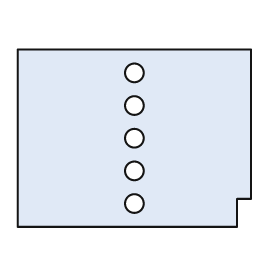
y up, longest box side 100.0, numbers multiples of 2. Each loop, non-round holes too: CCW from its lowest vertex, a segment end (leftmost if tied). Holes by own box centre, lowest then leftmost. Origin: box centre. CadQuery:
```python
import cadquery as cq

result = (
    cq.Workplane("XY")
    .moveTo(-50.0, -38.0)
    .lineTo(44.0, -38.0)
    .lineTo(44.0, -26.0)
    .lineTo(50.0, -26.0)
    .lineTo(50.0, 38.0)
    .lineTo(-50.0, 38.0)
    .close()
    .moveTo(0.0, -28.0)
    .circle(4.0)
    .moveTo(0.0, -14.0)
    .circle(4.0)
    .moveTo(0.0, 0.0)
    .circle(4.0)
    .moveTo(0.0, 14.0)
    .circle(4.0)
    .moveTo(0.0, 28.0)
    .circle(4.0)
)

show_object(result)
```